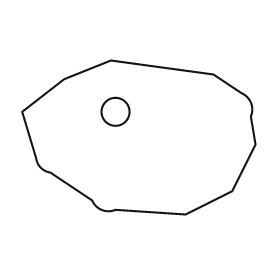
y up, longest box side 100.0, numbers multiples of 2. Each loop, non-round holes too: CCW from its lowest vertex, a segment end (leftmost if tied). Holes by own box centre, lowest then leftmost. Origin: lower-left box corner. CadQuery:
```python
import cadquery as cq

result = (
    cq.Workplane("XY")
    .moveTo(70.0, 0.0)
    .lineTo(90.0, 10.0)
    .lineTo(100.0, 30.0)
    .lineTo(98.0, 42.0)
    .threePointArc((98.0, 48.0), (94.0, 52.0))
    .lineTo(82.0, 60.0)
    .lineTo(38.0, 66.0)
    .lineTo(18.0, 58.0)
    .lineTo(0.0, 44.0)
    .lineTo(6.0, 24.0)
    .threePointArc((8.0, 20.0), (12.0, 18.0))
    .lineTo(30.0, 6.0)
    .threePointArc((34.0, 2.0), (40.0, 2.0))
    .close()
    .moveTo(40.0, 44.0)
    .circle(6.0)
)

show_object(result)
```